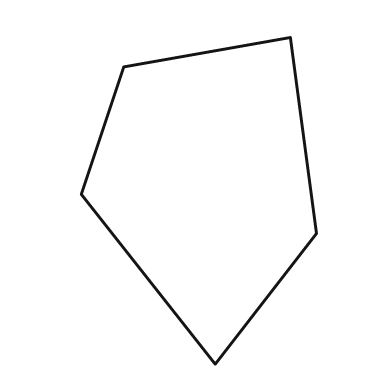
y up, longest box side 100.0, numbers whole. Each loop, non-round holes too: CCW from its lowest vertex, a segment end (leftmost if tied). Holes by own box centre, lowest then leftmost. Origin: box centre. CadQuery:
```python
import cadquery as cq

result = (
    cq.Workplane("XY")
    .moveTo(5.0, -50.0)
    .lineTo(36.0, -10.0)
    .lineTo(28.0, 50.0)
    .lineTo(-23.0, 41.0)
    .lineTo(-36.0, 2.0)
    .close()
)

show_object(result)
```